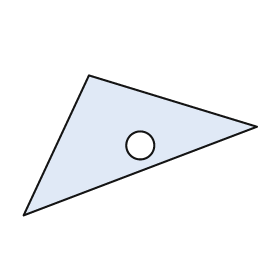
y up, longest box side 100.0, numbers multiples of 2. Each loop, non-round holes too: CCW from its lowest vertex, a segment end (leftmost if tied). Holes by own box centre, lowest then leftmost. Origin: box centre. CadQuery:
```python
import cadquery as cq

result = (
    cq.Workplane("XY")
    .moveTo(-50.0, -30.0)
    .lineTo(50.0, 8.0)
    .lineTo(-22.0, 30.0)
    .close()
    .moveTo(0.0, 0.0)
    .circle(6.0)
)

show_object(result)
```